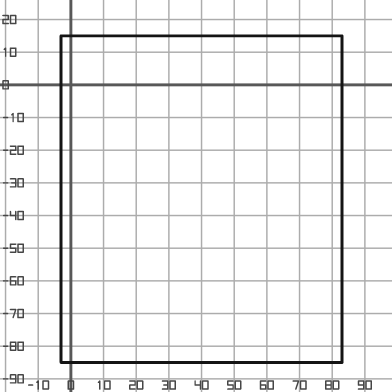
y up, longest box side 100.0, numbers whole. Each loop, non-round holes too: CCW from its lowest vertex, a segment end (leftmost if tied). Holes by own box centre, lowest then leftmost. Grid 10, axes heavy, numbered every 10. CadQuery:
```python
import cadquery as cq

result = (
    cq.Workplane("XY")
    .moveTo(-3.0, -85.0)
    .lineTo(83.0, -85.0)
    .lineTo(83.0, 15.0)
    .lineTo(-3.0, 15.0)
    .close()
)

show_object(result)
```